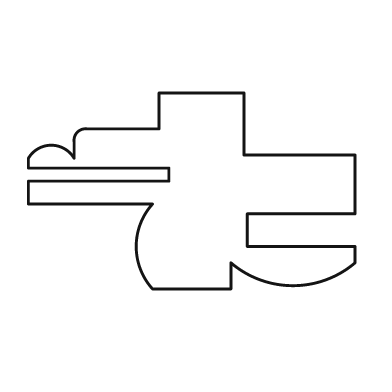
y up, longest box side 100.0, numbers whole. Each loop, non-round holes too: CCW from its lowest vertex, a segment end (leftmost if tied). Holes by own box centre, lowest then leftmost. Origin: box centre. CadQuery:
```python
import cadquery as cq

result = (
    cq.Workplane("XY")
    .moveTo(-12.0, -30.0)
    .lineTo(12.0, -30.0)
    .lineTo(12.0, -22.0)
    .threePointArc((31.0, -29.0), (50.0, -22.0))
    .lineTo(50.0, -17.0)
    .lineTo(17.0, -17.0)
    .lineTo(17.0, -7.0)
    .lineTo(50.0, -7.0)
    .lineTo(50.0, 11.0)
    .lineTo(16.0, 11.0)
    .lineTo(16.0, 30.0)
    .lineTo(-10.0, 30.0)
    .lineTo(-10.0, 19.0)
    .lineTo(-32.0, 19.0)
    .threePointArc((-35.0, 18.0), (-36.0, 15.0))
    .lineTo(-36.0, 10.0)
    .threePointArc((-43.0, 14.0), (-50.0, 10.0))
    .lineTo(-50.0, 7.0)
    .lineTo(-7.0, 7.0)
    .lineTo(-7.0, 3.0)
    .lineTo(-50.0, 3.0)
    .lineTo(-50.0, -4.0)
    .lineTo(-12.0, -4.0)
    .threePointArc((-17.0, -17.0), (-12.0, -30.0))
    .close()
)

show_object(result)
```